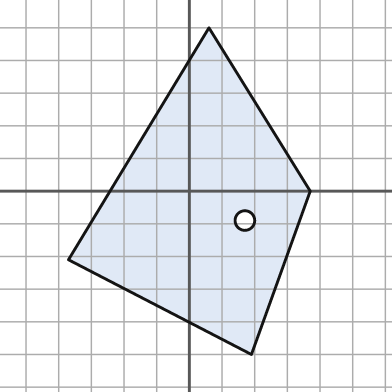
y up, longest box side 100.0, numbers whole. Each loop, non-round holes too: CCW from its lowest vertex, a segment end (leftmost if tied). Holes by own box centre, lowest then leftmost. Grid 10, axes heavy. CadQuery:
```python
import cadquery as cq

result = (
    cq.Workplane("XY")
    .moveTo(19.0, -50.0)
    .lineTo(37.0, 0.0)
    .lineTo(6.0, 50.0)
    .lineTo(-37.0, -21.0)
    .close()
    .moveTo(17.0, -9.0)
    .circle(3.0)
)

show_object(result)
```